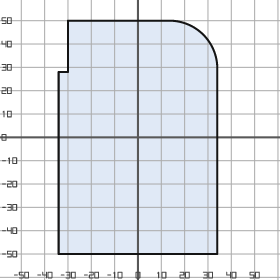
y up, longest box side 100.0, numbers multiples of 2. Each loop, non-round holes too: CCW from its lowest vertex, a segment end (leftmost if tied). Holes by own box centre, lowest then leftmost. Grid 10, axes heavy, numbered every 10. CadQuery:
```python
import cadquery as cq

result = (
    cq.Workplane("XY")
    .moveTo(-34.0, -50.0)
    .lineTo(34.0, -50.0)
    .lineTo(34.0, 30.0)
    .threePointArc((28.0, 44.0), (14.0, 50.0))
    .lineTo(-30.0, 50.0)
    .lineTo(-30.0, 28.0)
    .lineTo(-34.0, 28.0)
    .close()
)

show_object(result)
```